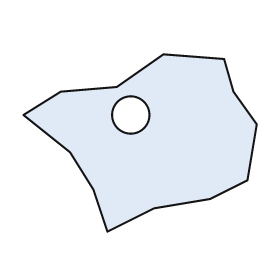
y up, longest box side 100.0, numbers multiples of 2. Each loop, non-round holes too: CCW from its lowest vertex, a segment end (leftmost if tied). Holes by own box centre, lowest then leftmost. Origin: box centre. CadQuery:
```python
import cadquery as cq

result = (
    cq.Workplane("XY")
    .moveTo(-14.0, -38.0)
    .lineTo(6.0, -28.0)
    .lineTo(30.0, -24.0)
    .lineTo(46.0, -16.0)
    .lineTo(50.0, 8.0)
    .lineTo(40.0, 22.0)
    .lineTo(36.0, 36.0)
    .lineTo(10.0, 38.0)
    .lineTo(-10.0, 24.0)
    .lineTo(-34.0, 22.0)
    .lineTo(-50.0, 12.0)
    .lineTo(-30.0, -4.0)
    .lineTo(-20.0, -20.0)
    .close()
    .moveTo(-4.0, 12.0)
    .circle(8.0)
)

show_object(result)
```